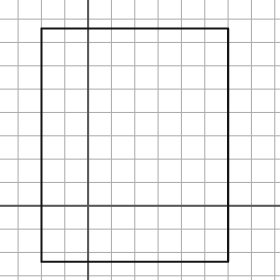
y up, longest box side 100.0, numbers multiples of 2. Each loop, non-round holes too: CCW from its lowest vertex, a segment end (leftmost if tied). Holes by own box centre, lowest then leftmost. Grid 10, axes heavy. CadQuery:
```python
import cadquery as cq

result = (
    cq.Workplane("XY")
    .moveTo(-20.0, -24.0)
    .lineTo(60.0, -24.0)
    .lineTo(60.0, 76.0)
    .lineTo(-20.0, 76.0)
    .close()
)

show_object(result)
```